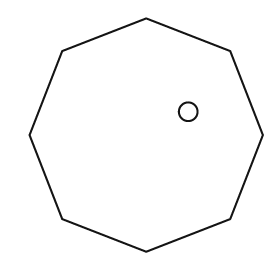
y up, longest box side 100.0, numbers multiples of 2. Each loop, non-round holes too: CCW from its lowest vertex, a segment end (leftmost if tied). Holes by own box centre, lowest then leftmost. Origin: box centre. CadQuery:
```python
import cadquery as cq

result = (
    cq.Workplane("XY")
    .moveTo(0.0, -50.0)
    .lineTo(36.0, -36.0)
    .lineTo(50.0, 0.0)
    .lineTo(36.0, 36.0)
    .lineTo(0.0, 50.0)
    .lineTo(-36.0, 36.0)
    .lineTo(-50.0, 0.0)
    .lineTo(-36.0, -36.0)
    .close()
    .moveTo(18.0, 10.0)
    .circle(4.0)
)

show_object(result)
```